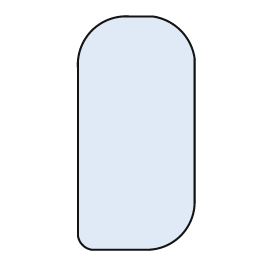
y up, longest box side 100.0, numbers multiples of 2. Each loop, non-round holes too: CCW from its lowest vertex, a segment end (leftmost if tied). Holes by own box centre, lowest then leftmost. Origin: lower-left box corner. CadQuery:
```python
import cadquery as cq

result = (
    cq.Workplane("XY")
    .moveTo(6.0, 0.0)
    .lineTo(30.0, 0.0)
    .threePointArc((44.0, 6.0), (50.0, 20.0))
    .lineTo(50.0, 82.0)
    .threePointArc((44.0, 94.0), (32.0, 100.0))
    .lineTo(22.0, 100.0)
    .threePointArc((6.0, 94.0), (0.0, 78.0))
    .lineTo(0.0, 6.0)
    .threePointArc((2.0, 2.0), (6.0, 0.0))
    .close()
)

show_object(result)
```